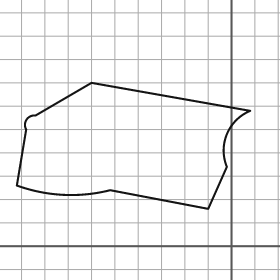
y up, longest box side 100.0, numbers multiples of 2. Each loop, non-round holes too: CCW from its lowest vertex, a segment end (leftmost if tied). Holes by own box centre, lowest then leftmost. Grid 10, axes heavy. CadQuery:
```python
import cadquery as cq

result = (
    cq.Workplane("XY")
    .moveTo(-10.0, 16.0)
    .lineTo(-2.0, 34.0)
    .threePointArc((-2.0, 48.0), (8.0, 58.0))
    .lineTo(-60.0, 70.0)
    .lineTo(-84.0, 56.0)
    .threePointArc((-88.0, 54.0), (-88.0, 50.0))
    .lineTo(-92.0, 26.0)
    .threePointArc((-72.0, 22.0), (-52.0, 24.0))
    .close()
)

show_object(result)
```